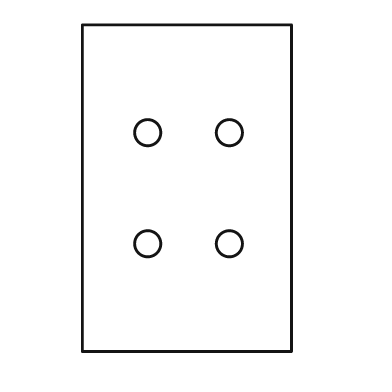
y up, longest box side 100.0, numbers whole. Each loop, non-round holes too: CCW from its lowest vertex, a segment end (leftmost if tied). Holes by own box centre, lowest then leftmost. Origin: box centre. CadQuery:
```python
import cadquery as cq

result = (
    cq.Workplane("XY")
    .moveTo(-32.0, -50.0)
    .lineTo(32.0, -50.0)
    .lineTo(32.0, 50.0)
    .lineTo(-32.0, 50.0)
    .close()
    .moveTo(-12.0, -17.0)
    .circle(4.0)
    .moveTo(13.0, -17.0)
    .circle(4.0)
    .moveTo(-12.0, 17.0)
    .circle(4.0)
    .moveTo(13.0, 17.0)
    .circle(4.0)
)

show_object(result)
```